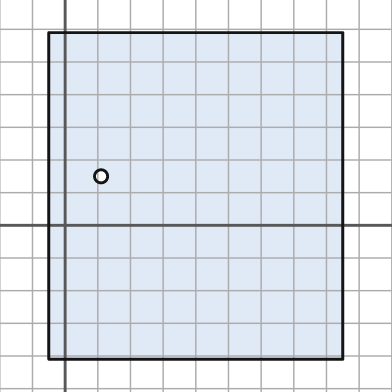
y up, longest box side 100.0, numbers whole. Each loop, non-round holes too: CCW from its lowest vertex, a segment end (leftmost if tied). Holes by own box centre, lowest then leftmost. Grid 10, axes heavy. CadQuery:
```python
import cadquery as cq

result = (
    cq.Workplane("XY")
    .moveTo(-5.0, -41.0)
    .lineTo(85.0, -41.0)
    .lineTo(85.0, 59.0)
    .lineTo(-5.0, 59.0)
    .close()
    .moveTo(11.0, 15.0)
    .circle(2.0)
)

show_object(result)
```